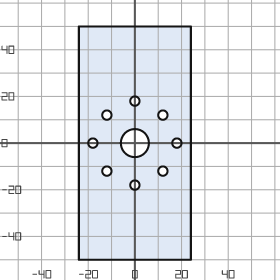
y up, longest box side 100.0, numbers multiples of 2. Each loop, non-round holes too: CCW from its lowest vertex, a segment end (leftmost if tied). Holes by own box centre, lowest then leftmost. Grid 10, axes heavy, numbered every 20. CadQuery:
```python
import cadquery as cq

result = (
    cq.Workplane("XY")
    .moveTo(-24.0, -50.0)
    .lineTo(24.0, -50.0)
    .lineTo(24.0, 50.0)
    .lineTo(-24.0, 50.0)
    .close()
    .moveTo(0.0, -18.0)
    .circle(2.0)
    .moveTo(-12.0, -12.0)
    .circle(2.0)
    .moveTo(12.0, -12.0)
    .circle(2.0)
    .moveTo(-18.0, 0.0)
    .circle(2.0)
    .moveTo(0.0, 0.0)
    .circle(6.0)
    .moveTo(18.0, 0.0)
    .circle(2.0)
    .moveTo(-12.0, 12.0)
    .circle(2.0)
    .moveTo(12.0, 12.0)
    .circle(2.0)
    .moveTo(0.0, 18.0)
    .circle(2.0)
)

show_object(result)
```